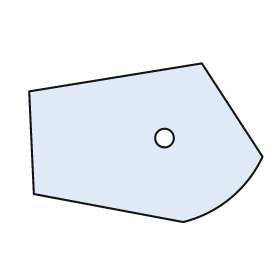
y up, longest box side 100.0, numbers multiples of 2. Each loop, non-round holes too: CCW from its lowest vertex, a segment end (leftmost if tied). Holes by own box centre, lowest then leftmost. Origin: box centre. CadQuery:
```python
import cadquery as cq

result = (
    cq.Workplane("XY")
    .moveTo(16.0, -34.0)
    .threePointArc((36.0, -24.0), (50.0, -6.0))
    .lineTo(24.0, 34.0)
    .lineTo(-50.0, 22.0)
    .lineTo(-48.0, -22.0)
    .close()
    .moveTo(8.0, 2.0)
    .circle(4.0)
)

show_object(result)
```